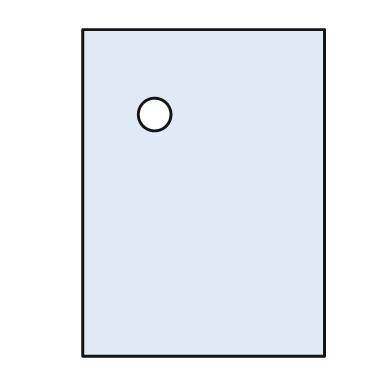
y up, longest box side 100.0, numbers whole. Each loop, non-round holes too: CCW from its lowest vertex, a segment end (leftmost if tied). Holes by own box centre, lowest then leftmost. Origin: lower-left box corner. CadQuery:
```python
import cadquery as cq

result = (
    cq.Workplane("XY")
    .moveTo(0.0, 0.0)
    .lineTo(74.0, 0.0)
    .lineTo(74.0, 100.0)
    .lineTo(0.0, 100.0)
    .close()
    .moveTo(22.0, 74.0)
    .circle(5.0)
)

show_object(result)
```